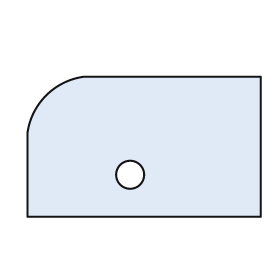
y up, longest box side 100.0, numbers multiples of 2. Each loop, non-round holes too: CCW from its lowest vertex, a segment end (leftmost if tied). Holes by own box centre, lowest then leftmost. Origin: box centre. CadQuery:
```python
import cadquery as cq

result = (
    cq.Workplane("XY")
    .moveTo(-50.0, -30.0)
    .lineTo(50.0, -30.0)
    .lineTo(50.0, 30.0)
    .lineTo(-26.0, 30.0)
    .threePointArc((-42.0, 22.0), (-50.0, 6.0))
    .close()
    .moveTo(-6.0, -12.0)
    .circle(6.0)
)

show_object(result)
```